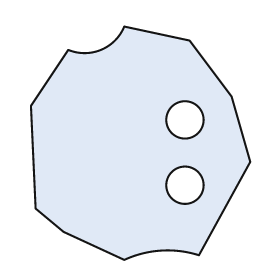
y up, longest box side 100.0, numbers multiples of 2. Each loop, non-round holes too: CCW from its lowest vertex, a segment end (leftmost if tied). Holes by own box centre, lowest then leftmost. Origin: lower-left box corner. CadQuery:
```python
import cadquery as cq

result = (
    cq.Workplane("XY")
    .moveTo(40.0, 0.0)
    .threePointArc((56.0, 4.0), (72.0, 2.0))
    .lineTo(94.0, 42.0)
    .lineTo(86.0, 70.0)
    .lineTo(68.0, 94.0)
    .lineTo(40.0, 100.0)
    .threePointArc((30.0, 90.0), (16.0, 90.0))
    .lineTo(0.0, 66.0)
    .lineTo(2.0, 22.0)
    .lineTo(14.0, 12.0)
    .close()
    .moveTo(66.0, 32.0)
    .circle(8.0)
    .moveTo(66.0, 60.0)
    .circle(8.0)
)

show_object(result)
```